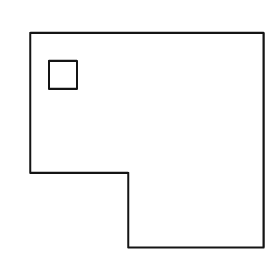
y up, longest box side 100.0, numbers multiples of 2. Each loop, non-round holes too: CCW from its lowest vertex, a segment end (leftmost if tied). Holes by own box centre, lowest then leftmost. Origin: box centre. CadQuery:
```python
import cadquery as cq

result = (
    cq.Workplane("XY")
    .moveTo(-8.0, -46.0)
    .lineTo(50.0, -46.0)
    .lineTo(50.0, 46.0)
    .lineTo(-50.0, 46.0)
    .lineTo(-50.0, -14.0)
    .lineTo(-8.0, -14.0)
    .close()
    .moveTo(-42.0, 22.0)
    .lineTo(-30.0, 22.0)
    .lineTo(-30.0, 34.0)
    .lineTo(-42.0, 34.0)
    .close()
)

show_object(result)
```